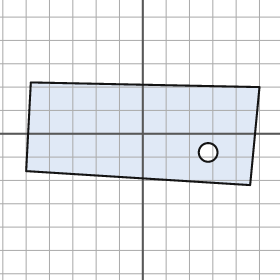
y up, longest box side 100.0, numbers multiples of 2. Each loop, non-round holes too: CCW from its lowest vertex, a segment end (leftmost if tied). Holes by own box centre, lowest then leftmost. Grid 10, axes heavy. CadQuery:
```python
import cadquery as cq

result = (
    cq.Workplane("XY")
    .moveTo(46.0, -22.0)
    .lineTo(50.0, 20.0)
    .lineTo(-48.0, 22.0)
    .lineTo(-50.0, -16.0)
    .close()
    .moveTo(28.0, -8.0)
    .circle(4.0)
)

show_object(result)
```